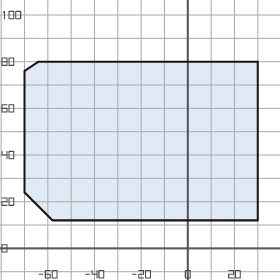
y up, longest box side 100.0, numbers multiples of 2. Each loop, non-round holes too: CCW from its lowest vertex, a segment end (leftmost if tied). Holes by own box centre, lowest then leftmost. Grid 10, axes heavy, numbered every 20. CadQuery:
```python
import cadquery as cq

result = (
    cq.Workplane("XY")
    .moveTo(-58.0, 12.0)
    .lineTo(30.0, 12.0)
    .lineTo(30.0, 80.0)
    .lineTo(-64.0, 80.0)
    .lineTo(-70.0, 76.0)
    .lineTo(-70.0, 24.0)
    .close()
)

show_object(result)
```